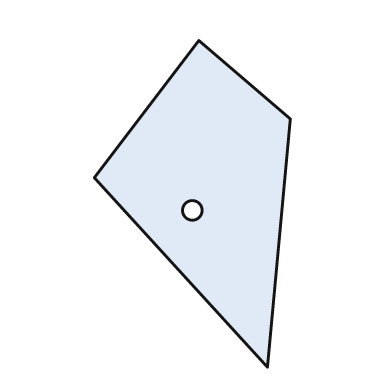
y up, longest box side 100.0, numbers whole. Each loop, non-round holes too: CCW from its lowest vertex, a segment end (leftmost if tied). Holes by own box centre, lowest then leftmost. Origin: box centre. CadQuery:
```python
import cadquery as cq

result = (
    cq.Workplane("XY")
    .moveTo(23.0, -50.0)
    .lineTo(30.0, 26.0)
    .lineTo(2.0, 50.0)
    .lineTo(-30.0, 8.0)
    .close()
    .moveTo(0.0, -2.0)
    .circle(3.0)
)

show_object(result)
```